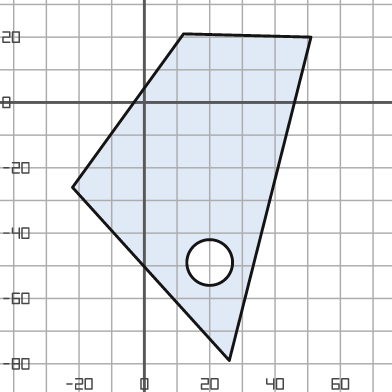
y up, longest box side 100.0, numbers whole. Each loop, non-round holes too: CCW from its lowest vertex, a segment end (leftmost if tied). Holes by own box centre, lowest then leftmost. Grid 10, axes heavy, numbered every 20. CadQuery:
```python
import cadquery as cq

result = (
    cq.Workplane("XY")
    .moveTo(26.0, -79.0)
    .lineTo(51.0, 20.0)
    .lineTo(12.0, 21.0)
    .lineTo(-22.0, -26.0)
    .close()
    .moveTo(20.0, -49.0)
    .circle(7.0)
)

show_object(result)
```